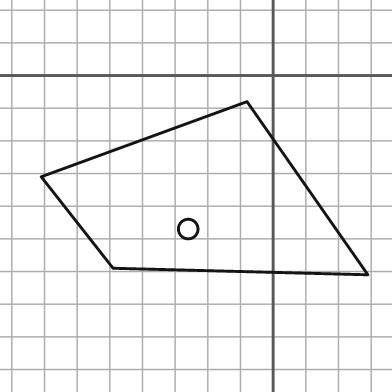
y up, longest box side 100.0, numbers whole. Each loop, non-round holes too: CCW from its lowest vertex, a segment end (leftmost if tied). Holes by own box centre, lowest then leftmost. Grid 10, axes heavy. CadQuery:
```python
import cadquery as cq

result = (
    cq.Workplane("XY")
    .moveTo(29.0, -61.0)
    .lineTo(-8.0, -8.0)
    .lineTo(-71.0, -31.0)
    .lineTo(-49.0, -59.0)
    .close()
    .moveTo(-26.0, -47.0)
    .circle(3.0)
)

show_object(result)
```